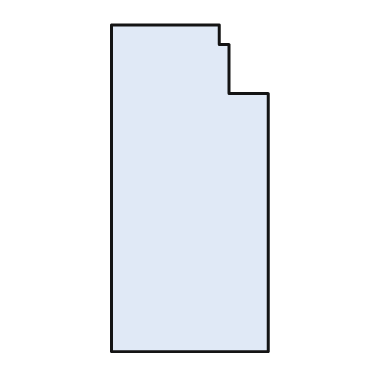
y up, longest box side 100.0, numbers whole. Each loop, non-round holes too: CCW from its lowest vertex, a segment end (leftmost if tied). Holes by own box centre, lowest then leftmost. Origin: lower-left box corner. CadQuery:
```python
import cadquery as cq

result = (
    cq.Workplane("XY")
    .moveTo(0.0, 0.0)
    .lineTo(48.0, 0.0)
    .lineTo(48.0, 79.0)
    .lineTo(36.0, 79.0)
    .lineTo(36.0, 94.0)
    .lineTo(33.0, 94.0)
    .lineTo(33.0, 100.0)
    .lineTo(0.0, 100.0)
    .close()
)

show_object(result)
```